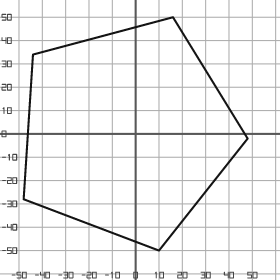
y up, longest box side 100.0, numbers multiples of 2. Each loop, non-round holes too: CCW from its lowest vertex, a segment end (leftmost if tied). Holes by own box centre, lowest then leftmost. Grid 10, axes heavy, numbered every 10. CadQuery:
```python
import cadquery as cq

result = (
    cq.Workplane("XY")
    .moveTo(10.0, -50.0)
    .lineTo(48.0, -2.0)
    .lineTo(16.0, 50.0)
    .lineTo(-44.0, 34.0)
    .lineTo(-48.0, -28.0)
    .close()
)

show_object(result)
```